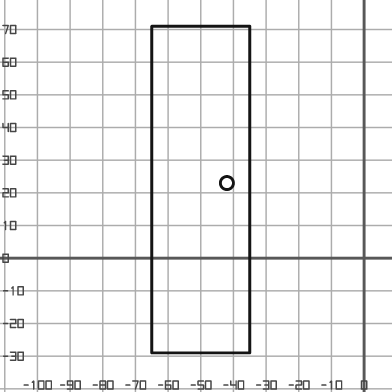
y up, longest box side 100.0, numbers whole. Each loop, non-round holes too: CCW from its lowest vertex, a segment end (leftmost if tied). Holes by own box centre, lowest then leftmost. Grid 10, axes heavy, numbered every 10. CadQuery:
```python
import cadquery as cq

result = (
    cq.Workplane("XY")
    .moveTo(-65.0, -29.0)
    .lineTo(-35.0, -29.0)
    .lineTo(-35.0, 71.0)
    .lineTo(-65.0, 71.0)
    .close()
    .moveTo(-42.0, 23.0)
    .circle(2.0)
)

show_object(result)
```